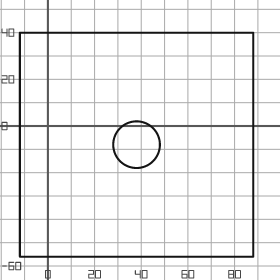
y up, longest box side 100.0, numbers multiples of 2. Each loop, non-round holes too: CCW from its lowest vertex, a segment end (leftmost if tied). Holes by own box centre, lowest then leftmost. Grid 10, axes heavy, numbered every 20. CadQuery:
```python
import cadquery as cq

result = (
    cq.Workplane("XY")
    .moveTo(-12.0, -56.0)
    .lineTo(88.0, -56.0)
    .lineTo(88.0, 40.0)
    .lineTo(-12.0, 40.0)
    .close()
    .moveTo(38.0, -8.0)
    .circle(10.0)
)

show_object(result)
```